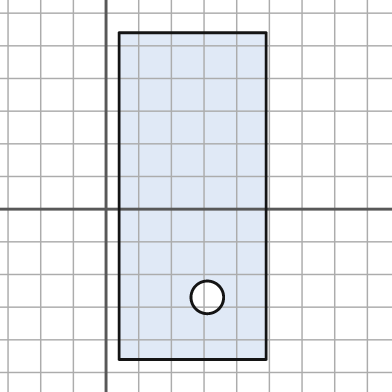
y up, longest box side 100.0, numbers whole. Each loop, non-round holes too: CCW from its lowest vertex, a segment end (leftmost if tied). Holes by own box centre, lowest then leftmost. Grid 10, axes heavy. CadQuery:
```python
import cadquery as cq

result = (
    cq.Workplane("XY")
    .moveTo(4.0, -46.0)
    .lineTo(49.0, -46.0)
    .lineTo(49.0, 54.0)
    .lineTo(4.0, 54.0)
    .close()
    .moveTo(31.0, -27.0)
    .circle(5.0)
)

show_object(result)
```